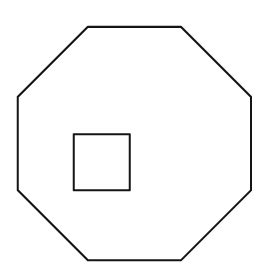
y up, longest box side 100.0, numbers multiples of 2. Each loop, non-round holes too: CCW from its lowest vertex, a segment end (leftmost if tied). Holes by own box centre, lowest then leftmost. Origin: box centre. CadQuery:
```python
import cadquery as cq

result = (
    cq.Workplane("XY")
    .moveTo(-20.0, -50.0)
    .lineTo(20.0, -50.0)
    .lineTo(50.0, -20.0)
    .lineTo(50.0, 20.0)
    .lineTo(20.0, 50.0)
    .lineTo(-20.0, 50.0)
    .lineTo(-50.0, 20.0)
    .lineTo(-50.0, -20.0)
    .close()
    .moveTo(-26.0, -20.0)
    .lineTo(-2.0, -20.0)
    .lineTo(-2.0, 4.0)
    .lineTo(-26.0, 4.0)
    .close()
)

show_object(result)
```